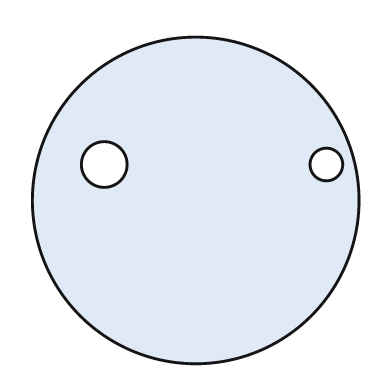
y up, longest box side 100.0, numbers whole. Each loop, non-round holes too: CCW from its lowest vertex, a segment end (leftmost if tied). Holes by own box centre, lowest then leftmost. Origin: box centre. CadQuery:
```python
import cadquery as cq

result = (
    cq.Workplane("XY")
    .moveTo(0.0, 0.0)
    .circle(50.0)
    .moveTo(-28.0, 11.0)
    .circle(7.0)
    .moveTo(40.0, 11.0)
    .circle(5.0)
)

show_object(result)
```